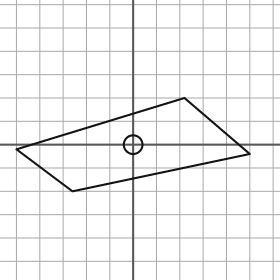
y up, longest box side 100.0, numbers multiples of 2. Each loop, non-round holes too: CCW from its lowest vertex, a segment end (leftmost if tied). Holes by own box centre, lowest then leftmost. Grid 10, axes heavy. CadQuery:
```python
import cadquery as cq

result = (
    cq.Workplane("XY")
    .moveTo(-26.0, -20.0)
    .lineTo(50.0, -4.0)
    .lineTo(22.0, 20.0)
    .lineTo(-50.0, -2.0)
    .close()
    .moveTo(0.0, 0.0)
    .circle(4.0)
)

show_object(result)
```